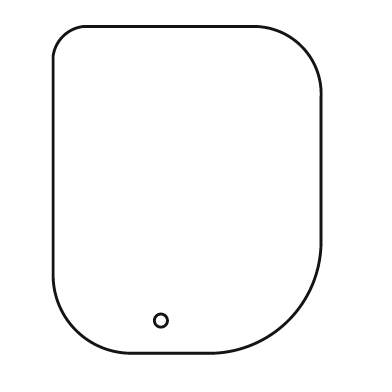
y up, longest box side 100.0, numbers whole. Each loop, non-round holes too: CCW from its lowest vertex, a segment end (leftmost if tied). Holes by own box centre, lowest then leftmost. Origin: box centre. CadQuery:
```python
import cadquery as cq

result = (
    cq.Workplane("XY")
    .moveTo(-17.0, -50.0)
    .lineTo(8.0, -50.0)
    .threePointArc((31.0, -40.0), (41.0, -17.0))
    .lineTo(41.0, 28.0)
    .threePointArc((35.0, 44.0), (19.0, 50.0))
    .lineTo(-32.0, 50.0)
    .threePointArc((-38.0, 47.0), (-41.0, 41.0))
    .lineTo(-41.0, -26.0)
    .threePointArc((-34.0, -43.0), (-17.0, -50.0))
    .close()
    .moveTo(-8.0, -40.0)
    .circle(2.0)
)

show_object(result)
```